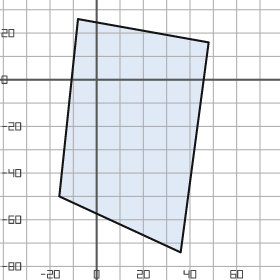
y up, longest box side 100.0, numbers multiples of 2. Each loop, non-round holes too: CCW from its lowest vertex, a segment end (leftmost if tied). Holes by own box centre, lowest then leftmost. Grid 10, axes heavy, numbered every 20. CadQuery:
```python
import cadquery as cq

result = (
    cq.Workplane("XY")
    .moveTo(36.0, -74.0)
    .lineTo(48.0, 16.0)
    .lineTo(-8.0, 26.0)
    .lineTo(-16.0, -50.0)
    .close()
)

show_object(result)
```